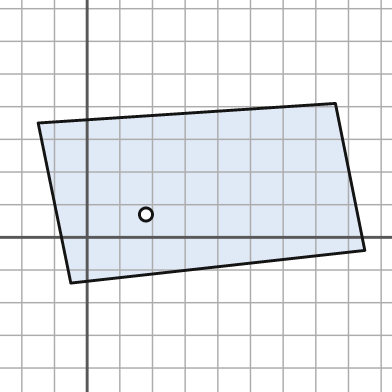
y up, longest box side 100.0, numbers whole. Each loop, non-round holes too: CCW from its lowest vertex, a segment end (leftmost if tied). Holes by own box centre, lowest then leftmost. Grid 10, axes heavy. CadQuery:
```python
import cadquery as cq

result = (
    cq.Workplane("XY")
    .moveTo(-5.0, -14.0)
    .lineTo(85.0, -4.0)
    .lineTo(76.0, 41.0)
    .lineTo(-15.0, 35.0)
    .close()
    .moveTo(18.0, 7.0)
    .circle(2.0)
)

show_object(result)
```